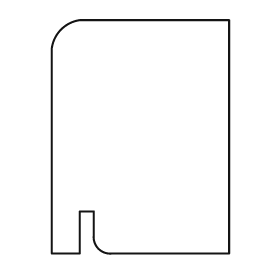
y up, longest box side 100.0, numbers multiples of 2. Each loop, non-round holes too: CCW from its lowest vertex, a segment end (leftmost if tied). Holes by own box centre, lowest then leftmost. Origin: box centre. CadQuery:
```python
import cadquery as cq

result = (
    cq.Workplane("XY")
    .moveTo(-38.0, -50.0)
    .lineTo(-26.0, -50.0)
    .lineTo(-26.0, -32.0)
    .lineTo(-20.0, -32.0)
    .lineTo(-20.0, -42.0)
    .threePointArc((-18.0, -48.0), (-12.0, -50.0))
    .lineTo(38.0, -50.0)
    .lineTo(38.0, 50.0)
    .lineTo(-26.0, 50.0)
    .threePointArc((-34.0, 46.0), (-38.0, 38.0))
    .close()
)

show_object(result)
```